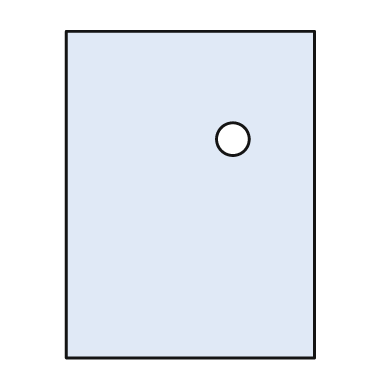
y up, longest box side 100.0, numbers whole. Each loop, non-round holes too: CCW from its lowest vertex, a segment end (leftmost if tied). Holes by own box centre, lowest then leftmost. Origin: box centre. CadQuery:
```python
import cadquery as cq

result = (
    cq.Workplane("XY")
    .moveTo(-38.0, -50.0)
    .lineTo(38.0, -50.0)
    .lineTo(38.0, 50.0)
    .lineTo(-38.0, 50.0)
    .close()
    .moveTo(13.0, 17.0)
    .circle(5.0)
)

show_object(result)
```